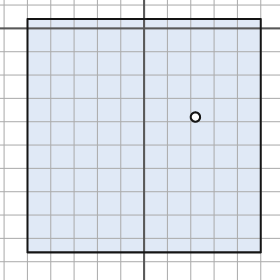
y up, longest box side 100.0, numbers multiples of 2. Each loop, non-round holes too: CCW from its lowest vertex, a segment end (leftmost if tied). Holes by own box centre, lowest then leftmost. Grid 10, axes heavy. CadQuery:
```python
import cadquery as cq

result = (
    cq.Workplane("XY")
    .moveTo(-50.0, -96.0)
    .lineTo(50.0, -96.0)
    .lineTo(50.0, 4.0)
    .lineTo(-50.0, 4.0)
    .close()
    .moveTo(22.0, -38.0)
    .circle(2.0)
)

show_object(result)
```